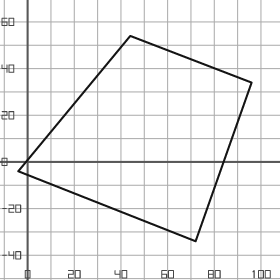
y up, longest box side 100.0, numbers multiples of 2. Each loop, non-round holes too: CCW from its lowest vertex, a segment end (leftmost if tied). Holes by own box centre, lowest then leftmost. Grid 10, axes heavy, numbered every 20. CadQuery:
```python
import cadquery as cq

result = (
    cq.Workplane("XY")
    .moveTo(72.0, -34.0)
    .lineTo(96.0, 34.0)
    .lineTo(44.0, 54.0)
    .lineTo(-4.0, -4.0)
    .close()
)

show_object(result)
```